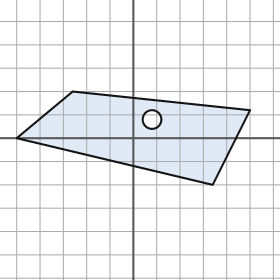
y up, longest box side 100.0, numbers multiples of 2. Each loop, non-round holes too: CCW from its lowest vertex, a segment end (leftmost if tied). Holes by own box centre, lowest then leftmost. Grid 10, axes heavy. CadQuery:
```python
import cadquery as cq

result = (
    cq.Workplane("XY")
    .moveTo(34.0, -20.0)
    .lineTo(50.0, 12.0)
    .lineTo(-26.0, 20.0)
    .lineTo(-50.0, 0.0)
    .close()
    .moveTo(8.0, 8.0)
    .circle(4.0)
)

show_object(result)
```